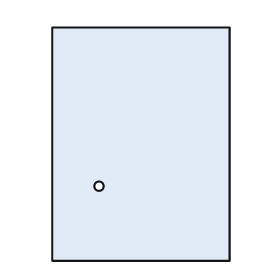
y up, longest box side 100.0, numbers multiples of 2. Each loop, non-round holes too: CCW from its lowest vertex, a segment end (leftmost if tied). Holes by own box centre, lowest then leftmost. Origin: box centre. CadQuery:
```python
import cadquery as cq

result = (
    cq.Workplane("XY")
    .moveTo(-38.0, -50.0)
    .lineTo(38.0, -50.0)
    .lineTo(38.0, 50.0)
    .lineTo(-38.0, 50.0)
    .close()
    .moveTo(-18.0, -18.0)
    .circle(2.0)
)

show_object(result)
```